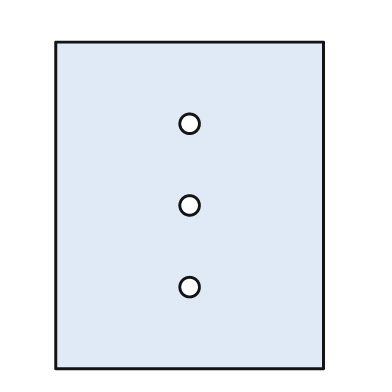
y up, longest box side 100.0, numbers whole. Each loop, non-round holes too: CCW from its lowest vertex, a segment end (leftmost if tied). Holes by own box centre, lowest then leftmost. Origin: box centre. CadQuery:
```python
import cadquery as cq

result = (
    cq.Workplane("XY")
    .moveTo(-41.0, -50.0)
    .lineTo(41.0, -50.0)
    .lineTo(41.0, 50.0)
    .lineTo(-41.0, 50.0)
    .close()
    .moveTo(0.0, -25.0)
    .circle(3.0)
    .moveTo(0.0, 0.0)
    .circle(3.0)
    .moveTo(0.0, 25.0)
    .circle(3.0)
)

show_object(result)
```